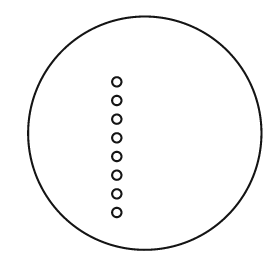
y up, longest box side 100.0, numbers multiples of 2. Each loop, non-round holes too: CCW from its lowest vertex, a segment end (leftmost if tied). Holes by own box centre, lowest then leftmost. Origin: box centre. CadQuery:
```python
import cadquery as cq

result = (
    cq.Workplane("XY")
    .moveTo(0.0, 0.0)
    .circle(50.0)
    .moveTo(-12.0, -34.0)
    .circle(2.0)
    .moveTo(-12.0, -26.0)
    .circle(2.0)
    .moveTo(-12.0, -18.0)
    .circle(2.0)
    .moveTo(-12.0, -10.0)
    .circle(2.0)
    .moveTo(-12.0, -2.0)
    .circle(2.0)
    .moveTo(-12.0, 6.0)
    .circle(2.0)
    .moveTo(-12.0, 14.0)
    .circle(2.0)
    .moveTo(-12.0, 22.0)
    .circle(2.0)
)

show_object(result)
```